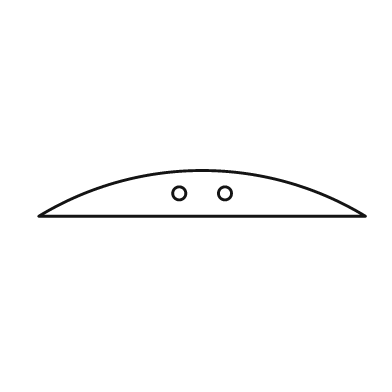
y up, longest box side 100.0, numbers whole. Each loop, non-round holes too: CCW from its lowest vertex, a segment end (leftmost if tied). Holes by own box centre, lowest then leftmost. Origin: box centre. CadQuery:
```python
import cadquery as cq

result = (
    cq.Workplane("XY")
    .moveTo(-50.0, -7.0)
    .lineTo(50.0, -7.0)
    .threePointArc((0.0, 7.0), (-50.0, -7.0))
    .close()
    .moveTo(-7.0, 0.0)
    .circle(2.0)
    .moveTo(7.0, 0.0)
    .circle(2.0)
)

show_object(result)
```